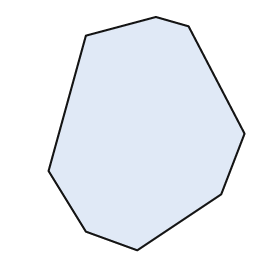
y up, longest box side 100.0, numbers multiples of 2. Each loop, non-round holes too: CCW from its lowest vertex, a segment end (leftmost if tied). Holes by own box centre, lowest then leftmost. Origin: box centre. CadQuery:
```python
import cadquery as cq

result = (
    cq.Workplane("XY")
    .moveTo(-4.0, -50.0)
    .lineTo(32.0, -26.0)
    .lineTo(42.0, 0.0)
    .lineTo(18.0, 46.0)
    .lineTo(4.0, 50.0)
    .lineTo(-26.0, 42.0)
    .lineTo(-42.0, -16.0)
    .lineTo(-26.0, -42.0)
    .close()
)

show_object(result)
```